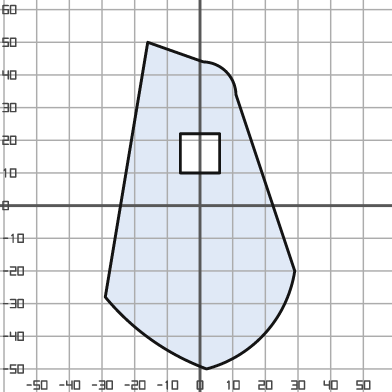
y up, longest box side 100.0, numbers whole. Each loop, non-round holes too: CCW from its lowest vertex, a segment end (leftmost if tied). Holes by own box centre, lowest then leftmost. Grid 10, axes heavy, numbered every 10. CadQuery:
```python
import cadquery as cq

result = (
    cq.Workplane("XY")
    .moveTo(2.0, -50.0)
    .threePointArc((20.0, -39.0), (29.0, -20.0))
    .lineTo(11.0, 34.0)
    .threePointArc((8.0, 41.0), (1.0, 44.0))
    .lineTo(-16.0, 50.0)
    .lineTo(-29.0, -28.0)
    .threePointArc((-15.0, -41.0), (2.0, -50.0))
    .close()
    .moveTo(-6.0, 10.0)
    .lineTo(6.0, 10.0)
    .lineTo(6.0, 22.0)
    .lineTo(-6.0, 22.0)
    .close()
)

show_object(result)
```